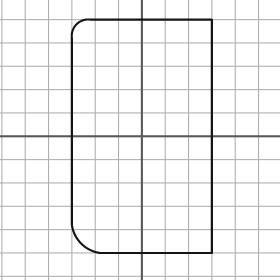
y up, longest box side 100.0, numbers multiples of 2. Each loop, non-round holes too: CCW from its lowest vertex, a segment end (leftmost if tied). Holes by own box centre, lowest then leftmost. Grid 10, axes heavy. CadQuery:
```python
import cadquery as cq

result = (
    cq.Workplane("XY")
    .moveTo(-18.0, -50.0)
    .lineTo(30.0, -50.0)
    .lineTo(30.0, 50.0)
    .lineTo(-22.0, 50.0)
    .threePointArc((-28.0, 48.0), (-30.0, 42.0))
    .lineTo(-30.0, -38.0)
    .threePointArc((-26.0, -46.0), (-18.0, -50.0))
    .close()
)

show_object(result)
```